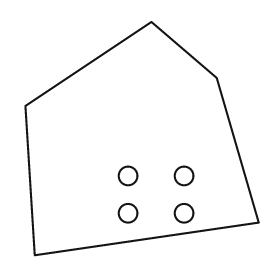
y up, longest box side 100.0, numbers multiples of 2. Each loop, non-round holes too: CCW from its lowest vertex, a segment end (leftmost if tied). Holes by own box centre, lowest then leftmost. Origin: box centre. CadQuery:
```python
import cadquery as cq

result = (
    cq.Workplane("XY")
    .moveTo(-46.0, -50.0)
    .lineTo(50.0, -36.0)
    .lineTo(32.0, 26.0)
    .lineTo(4.0, 50.0)
    .lineTo(-50.0, 14.0)
    .close()
    .moveTo(-6.0, -32.0)
    .circle(4.0)
    .moveTo(18.0, -32.0)
    .circle(4.0)
    .moveTo(-6.0, -16.0)
    .circle(4.0)
    .moveTo(18.0, -16.0)
    .circle(4.0)
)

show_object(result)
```